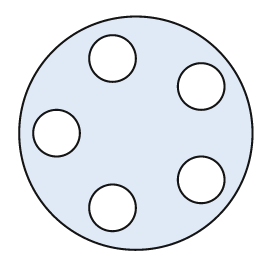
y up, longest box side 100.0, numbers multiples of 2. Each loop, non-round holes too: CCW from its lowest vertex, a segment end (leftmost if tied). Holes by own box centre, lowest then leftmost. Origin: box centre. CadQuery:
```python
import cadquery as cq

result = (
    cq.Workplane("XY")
    .moveTo(0.0, 0.0)
    .circle(50.0)
    .moveTo(-10.0, -32.0)
    .circle(10.0)
    .moveTo(28.0, -20.0)
    .circle(10.0)
    .moveTo(-34.0, 0.0)
    .circle(10.0)
    .moveTo(28.0, 20.0)
    .circle(10.0)
    .moveTo(-10.0, 32.0)
    .circle(10.0)
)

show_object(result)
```